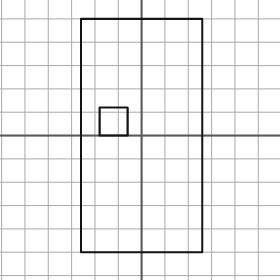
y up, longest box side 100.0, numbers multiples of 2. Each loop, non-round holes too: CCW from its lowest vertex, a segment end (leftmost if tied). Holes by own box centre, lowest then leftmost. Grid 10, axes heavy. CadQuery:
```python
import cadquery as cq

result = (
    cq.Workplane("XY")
    .moveTo(-26.0, -50.0)
    .lineTo(26.0, -50.0)
    .lineTo(26.0, 50.0)
    .lineTo(-26.0, 50.0)
    .close()
    .moveTo(-18.0, 0.0)
    .lineTo(-6.0, 0.0)
    .lineTo(-6.0, 12.0)
    .lineTo(-18.0, 12.0)
    .close()
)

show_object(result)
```